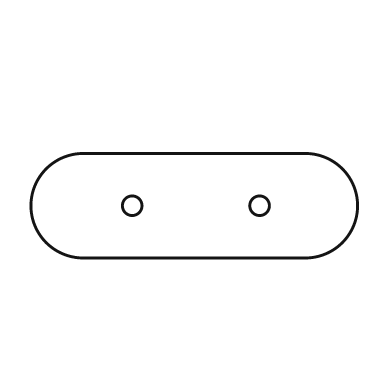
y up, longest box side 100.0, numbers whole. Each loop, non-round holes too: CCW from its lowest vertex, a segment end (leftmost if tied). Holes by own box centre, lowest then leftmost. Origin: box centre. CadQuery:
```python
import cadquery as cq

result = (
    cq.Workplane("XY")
    .moveTo(-34.0, -16.0)
    .lineTo(34.0, -16.0)
    .threePointArc((50.0, 0.0), (34.0, 16.0))
    .lineTo(-34.0, 16.0)
    .threePointArc((-50.0, 0.0), (-34.0, -16.0))
    .close()
    .moveTo(-19.0, 0.0)
    .circle(3.0)
    .moveTo(20.0, 0.0)
    .circle(3.0)
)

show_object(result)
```